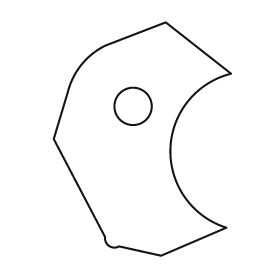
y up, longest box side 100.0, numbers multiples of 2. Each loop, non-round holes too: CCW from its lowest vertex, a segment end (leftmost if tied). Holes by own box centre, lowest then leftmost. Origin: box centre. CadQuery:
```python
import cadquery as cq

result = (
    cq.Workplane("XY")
    .moveTo(8.0, -50.0)
    .lineTo(36.0, -38.0)
    .threePointArc((12.0, -4.0), (38.0, 28.0))
    .lineTo(10.0, 50.0)
    .lineTo(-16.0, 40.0)
    .threePointArc((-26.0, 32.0), (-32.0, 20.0))
    .lineTo(-38.0, 0.0)
    .lineTo(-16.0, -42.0)
    .threePointArc((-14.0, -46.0), (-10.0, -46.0))
    .close()
    .moveTo(-4.0, 14.0)
    .circle(8.0)
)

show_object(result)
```